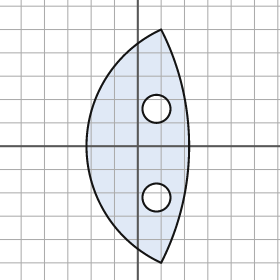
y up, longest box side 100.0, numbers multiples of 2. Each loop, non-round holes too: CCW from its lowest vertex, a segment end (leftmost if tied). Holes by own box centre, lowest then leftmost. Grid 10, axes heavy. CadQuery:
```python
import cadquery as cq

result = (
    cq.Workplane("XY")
    .moveTo(10.0, -50.0)
    .threePointArc((22.0, 0.0), (10.0, 50.0))
    .threePointArc((-22.0, 0.0), (10.0, -50.0))
    .close()
    .moveTo(8.0, -22.0)
    .circle(6.0)
    .moveTo(8.0, 16.0)
    .circle(6.0)
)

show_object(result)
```